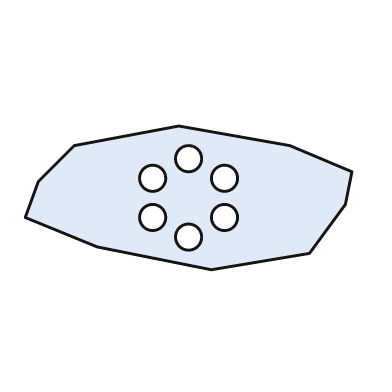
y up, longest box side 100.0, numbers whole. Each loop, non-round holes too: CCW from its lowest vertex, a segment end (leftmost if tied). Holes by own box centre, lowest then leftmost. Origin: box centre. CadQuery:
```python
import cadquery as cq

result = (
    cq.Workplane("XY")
    .moveTo(7.0, -22.0)
    .lineTo(37.0, -17.0)
    .lineTo(48.0, -2.0)
    .lineTo(50.0, 8.0)
    .lineTo(31.0, 16.0)
    .lineTo(-3.0, 22.0)
    .lineTo(-35.0, 16.0)
    .lineTo(-46.0, 5.0)
    .lineTo(-50.0, -6.0)
    .lineTo(-28.0, -15.0)
    .close()
    .moveTo(0.0, -12.0)
    .circle(4.0)
    .moveTo(-11.0, -6.0)
    .circle(4.0)
    .moveTo(11.0, -6.0)
    .circle(4.0)
    .moveTo(-11.0, 6.0)
    .circle(4.0)
    .moveTo(11.0, 6.0)
    .circle(4.0)
    .moveTo(0.0, 12.0)
    .circle(4.0)
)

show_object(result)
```